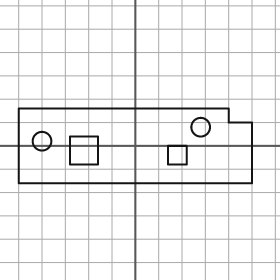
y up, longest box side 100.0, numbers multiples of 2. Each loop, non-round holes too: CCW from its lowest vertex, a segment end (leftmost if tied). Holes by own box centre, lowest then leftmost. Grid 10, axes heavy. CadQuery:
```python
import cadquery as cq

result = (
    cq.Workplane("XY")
    .moveTo(-50.0, -16.0)
    .lineTo(50.0, -16.0)
    .lineTo(50.0, 10.0)
    .lineTo(40.0, 10.0)
    .lineTo(40.0, 16.0)
    .lineTo(-50.0, 16.0)
    .close()
    .moveTo(14.0, -8.0)
    .lineTo(22.0, -8.0)
    .lineTo(22.0, 0.0)
    .lineTo(14.0, 0.0)
    .close()
    .moveTo(-28.0, -8.0)
    .lineTo(-16.0, -8.0)
    .lineTo(-16.0, 4.0)
    .lineTo(-28.0, 4.0)
    .close()
    .moveTo(-40.0, 2.0)
    .circle(4.0)
    .moveTo(28.0, 8.0)
    .circle(4.0)
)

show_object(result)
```